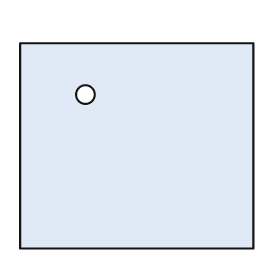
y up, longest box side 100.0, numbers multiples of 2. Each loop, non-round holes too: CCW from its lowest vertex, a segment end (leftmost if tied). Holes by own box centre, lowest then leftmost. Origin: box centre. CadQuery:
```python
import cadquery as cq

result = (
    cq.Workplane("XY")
    .moveTo(-50.0, -44.0)
    .lineTo(50.0, -44.0)
    .lineTo(50.0, 44.0)
    .lineTo(-50.0, 44.0)
    .close()
    .moveTo(-22.0, 22.0)
    .circle(4.0)
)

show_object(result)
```